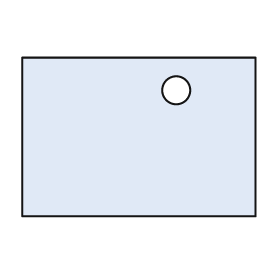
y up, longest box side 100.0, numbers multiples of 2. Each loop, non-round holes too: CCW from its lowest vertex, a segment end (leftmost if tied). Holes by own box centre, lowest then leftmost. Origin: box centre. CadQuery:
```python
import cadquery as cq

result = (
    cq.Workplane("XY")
    .moveTo(-50.0, -34.0)
    .lineTo(50.0, -34.0)
    .lineTo(50.0, 34.0)
    .lineTo(-50.0, 34.0)
    .close()
    .moveTo(16.0, 20.0)
    .circle(6.0)
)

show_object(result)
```